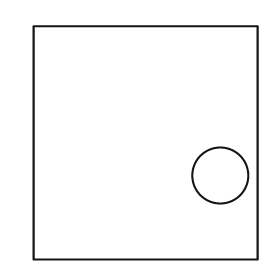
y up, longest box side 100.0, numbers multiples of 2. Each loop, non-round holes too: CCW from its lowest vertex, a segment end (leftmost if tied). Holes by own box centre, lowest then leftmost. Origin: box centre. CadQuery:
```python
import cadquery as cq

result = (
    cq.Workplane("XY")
    .moveTo(-48.0, -50.0)
    .lineTo(48.0, -50.0)
    .lineTo(48.0, 50.0)
    .lineTo(-48.0, 50.0)
    .close()
    .moveTo(32.0, -14.0)
    .circle(12.0)
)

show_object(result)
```